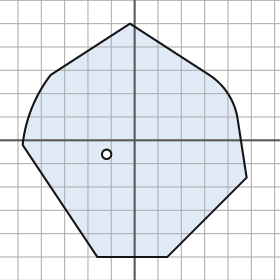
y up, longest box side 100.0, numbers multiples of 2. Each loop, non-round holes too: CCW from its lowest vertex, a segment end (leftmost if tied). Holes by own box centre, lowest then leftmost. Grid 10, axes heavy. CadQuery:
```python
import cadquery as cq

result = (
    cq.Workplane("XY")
    .moveTo(-16.0, -50.0)
    .lineTo(14.0, -50.0)
    .lineTo(48.0, -16.0)
    .lineTo(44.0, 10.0)
    .threePointArc((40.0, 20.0), (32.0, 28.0))
    .lineTo(-2.0, 50.0)
    .lineTo(-36.0, 28.0)
    .threePointArc((-44.0, 14.0), (-48.0, -2.0))
    .close()
    .moveTo(-12.0, -6.0)
    .circle(2.0)
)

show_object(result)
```